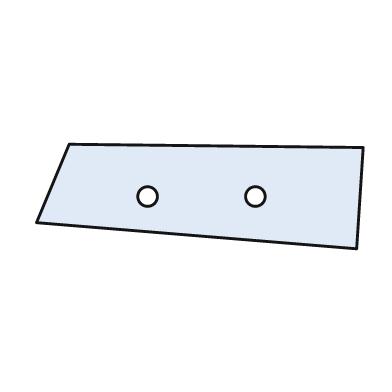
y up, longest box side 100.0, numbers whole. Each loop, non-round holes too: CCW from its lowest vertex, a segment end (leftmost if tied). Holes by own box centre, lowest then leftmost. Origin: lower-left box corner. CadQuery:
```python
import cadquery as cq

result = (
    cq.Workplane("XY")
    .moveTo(98.0, 0.0)
    .lineTo(100.0, 31.0)
    .lineTo(10.0, 32.0)
    .lineTo(0.0, 8.0)
    .close()
    .moveTo(34.0, 16.0)
    .circle(3.0)
    .moveTo(67.0, 16.0)
    .circle(3.0)
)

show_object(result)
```